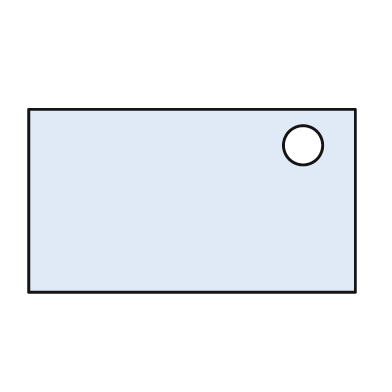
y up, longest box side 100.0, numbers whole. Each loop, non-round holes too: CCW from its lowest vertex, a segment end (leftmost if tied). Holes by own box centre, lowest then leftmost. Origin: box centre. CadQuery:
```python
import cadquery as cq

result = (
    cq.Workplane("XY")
    .moveTo(-50.0, -28.0)
    .lineTo(50.0, -28.0)
    .lineTo(50.0, 28.0)
    .lineTo(-50.0, 28.0)
    .close()
    .moveTo(34.0, 17.0)
    .circle(6.0)
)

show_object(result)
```